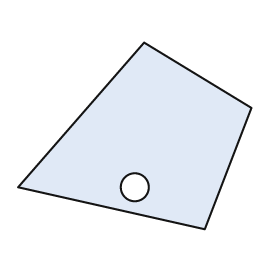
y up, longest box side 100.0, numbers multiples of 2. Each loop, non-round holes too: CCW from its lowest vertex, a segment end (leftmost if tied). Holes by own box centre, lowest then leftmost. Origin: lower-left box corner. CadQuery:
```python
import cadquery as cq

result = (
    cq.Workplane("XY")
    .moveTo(80.0, 0.0)
    .lineTo(100.0, 52.0)
    .lineTo(54.0, 80.0)
    .lineTo(0.0, 18.0)
    .close()
    .moveTo(50.0, 18.0)
    .circle(6.0)
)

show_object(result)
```